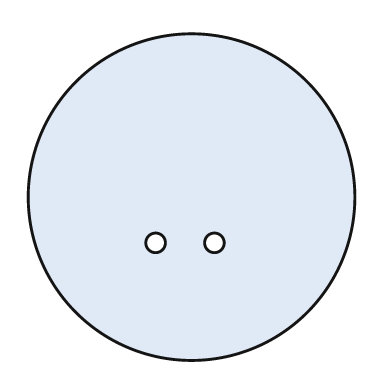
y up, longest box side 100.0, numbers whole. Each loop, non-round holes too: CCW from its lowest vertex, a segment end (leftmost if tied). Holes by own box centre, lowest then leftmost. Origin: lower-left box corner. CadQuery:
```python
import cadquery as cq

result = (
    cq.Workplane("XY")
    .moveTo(50.0, 50.0)
    .circle(50.0)
    .moveTo(39.0, 36.0)
    .circle(3.0)
    .moveTo(57.0, 36.0)
    .circle(3.0)
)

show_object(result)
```